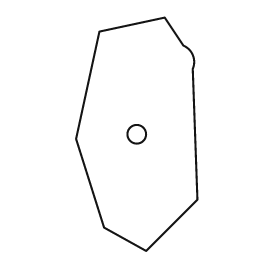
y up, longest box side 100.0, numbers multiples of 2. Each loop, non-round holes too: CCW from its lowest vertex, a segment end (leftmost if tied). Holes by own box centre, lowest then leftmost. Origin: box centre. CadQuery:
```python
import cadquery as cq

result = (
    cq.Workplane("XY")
    .moveTo(4.0, -50.0)
    .lineTo(26.0, -28.0)
    .lineTo(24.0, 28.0)
    .threePointArc((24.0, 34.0), (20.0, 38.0))
    .lineTo(12.0, 50.0)
    .lineTo(-16.0, 44.0)
    .lineTo(-26.0, -2.0)
    .lineTo(-14.0, -40.0)
    .close()
    .moveTo(0.0, 0.0)
    .circle(4.0)
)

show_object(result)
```